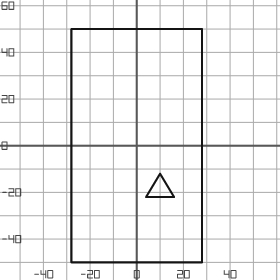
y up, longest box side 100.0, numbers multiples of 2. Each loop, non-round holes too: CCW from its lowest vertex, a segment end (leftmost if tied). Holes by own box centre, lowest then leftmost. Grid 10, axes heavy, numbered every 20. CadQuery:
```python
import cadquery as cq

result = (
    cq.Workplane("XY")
    .moveTo(-28.0, -50.0)
    .lineTo(28.0, -50.0)
    .lineTo(28.0, 50.0)
    .lineTo(-28.0, 50.0)
    .close()
    .moveTo(4.0, -22.0)
    .lineTo(16.0, -22.0)
    .lineTo(10.0, -12.0)
    .close()
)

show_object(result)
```